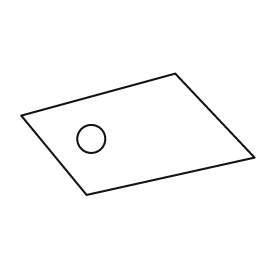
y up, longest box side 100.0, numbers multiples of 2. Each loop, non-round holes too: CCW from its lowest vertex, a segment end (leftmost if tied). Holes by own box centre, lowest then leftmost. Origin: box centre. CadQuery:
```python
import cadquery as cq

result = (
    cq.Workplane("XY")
    .moveTo(-22.0, -26.0)
    .lineTo(50.0, -10.0)
    .lineTo(16.0, 26.0)
    .lineTo(-50.0, 8.0)
    .close()
    .moveTo(-20.0, -2.0)
    .circle(6.0)
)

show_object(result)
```